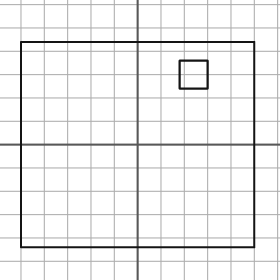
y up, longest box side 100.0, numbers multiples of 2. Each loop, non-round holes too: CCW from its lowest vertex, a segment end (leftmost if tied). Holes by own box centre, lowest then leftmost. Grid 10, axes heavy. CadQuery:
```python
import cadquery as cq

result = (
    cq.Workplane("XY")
    .moveTo(-50.0, -44.0)
    .lineTo(50.0, -44.0)
    .lineTo(50.0, 44.0)
    .lineTo(-50.0, 44.0)
    .close()
    .moveTo(18.0, 24.0)
    .lineTo(30.0, 24.0)
    .lineTo(30.0, 36.0)
    .lineTo(18.0, 36.0)
    .close()
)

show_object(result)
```